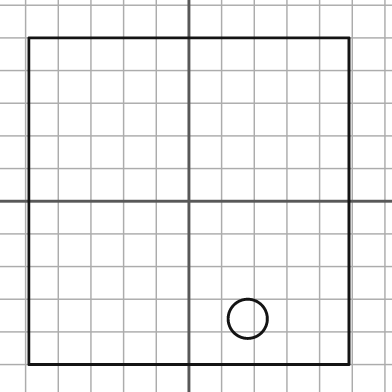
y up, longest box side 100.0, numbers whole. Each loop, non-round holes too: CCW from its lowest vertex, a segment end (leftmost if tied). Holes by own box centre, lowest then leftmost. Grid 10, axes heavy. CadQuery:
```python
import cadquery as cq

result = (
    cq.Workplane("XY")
    .moveTo(-49.0, -50.0)
    .lineTo(49.0, -50.0)
    .lineTo(49.0, 50.0)
    .lineTo(-49.0, 50.0)
    .close()
    .moveTo(18.0, -36.0)
    .circle(6.0)
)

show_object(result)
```